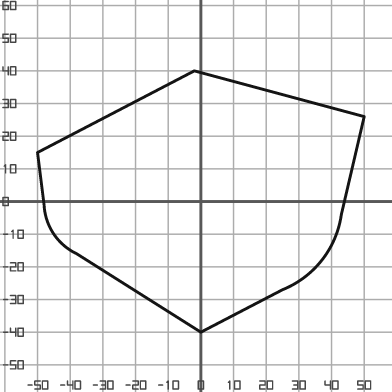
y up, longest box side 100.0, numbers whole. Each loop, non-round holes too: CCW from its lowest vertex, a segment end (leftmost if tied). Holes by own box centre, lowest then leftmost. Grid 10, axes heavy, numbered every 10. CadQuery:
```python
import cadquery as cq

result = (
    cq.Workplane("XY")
    .moveTo(0.0, -40.0)
    .lineTo(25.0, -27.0)
    .threePointArc((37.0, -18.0), (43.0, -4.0))
    .lineTo(50.0, 26.0)
    .lineTo(-2.0, 40.0)
    .lineTo(-50.0, 15.0)
    .lineTo(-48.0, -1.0)
    .threePointArc((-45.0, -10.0), (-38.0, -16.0))
    .close()
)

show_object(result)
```